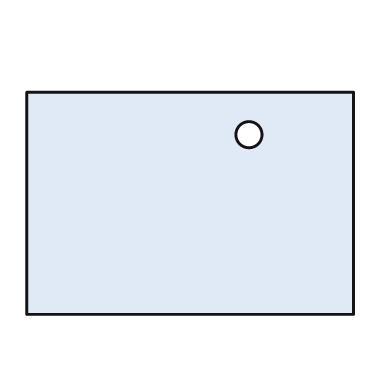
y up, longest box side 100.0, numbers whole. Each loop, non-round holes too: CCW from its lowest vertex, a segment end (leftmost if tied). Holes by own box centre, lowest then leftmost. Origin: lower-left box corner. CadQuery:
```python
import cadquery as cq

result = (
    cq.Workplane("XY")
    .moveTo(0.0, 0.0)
    .lineTo(100.0, 0.0)
    .lineTo(100.0, 68.0)
    .lineTo(0.0, 68.0)
    .close()
    .moveTo(68.0, 55.0)
    .circle(4.0)
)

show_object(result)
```